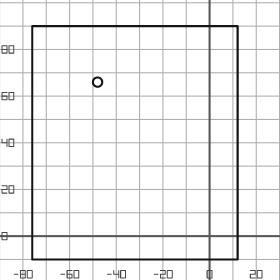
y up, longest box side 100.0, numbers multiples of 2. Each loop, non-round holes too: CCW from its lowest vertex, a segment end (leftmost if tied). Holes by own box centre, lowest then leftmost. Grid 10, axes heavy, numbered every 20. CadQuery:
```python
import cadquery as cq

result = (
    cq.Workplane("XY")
    .moveTo(-76.0, -10.0)
    .lineTo(12.0, -10.0)
    .lineTo(12.0, 90.0)
    .lineTo(-76.0, 90.0)
    .close()
    .moveTo(-48.0, 66.0)
    .circle(2.0)
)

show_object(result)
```